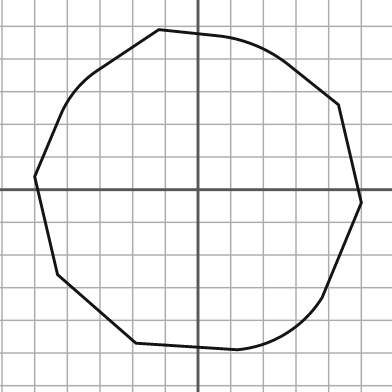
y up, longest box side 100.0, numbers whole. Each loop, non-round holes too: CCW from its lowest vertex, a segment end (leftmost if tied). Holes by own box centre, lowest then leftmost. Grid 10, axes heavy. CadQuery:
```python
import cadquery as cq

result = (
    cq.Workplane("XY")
    .moveTo(12.0, -49.0)
    .threePointArc((27.0, -44.0), (38.0, -33.0))
    .lineTo(50.0, -4.0)
    .lineTo(43.0, 26.0)
    .lineTo(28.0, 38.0)
    .threePointArc((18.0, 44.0), (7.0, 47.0))
    .lineTo(-12.0, 49.0)
    .lineTo(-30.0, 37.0)
    .threePointArc((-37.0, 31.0), (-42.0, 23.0))
    .lineTo(-50.0, 4.0)
    .lineTo(-43.0, -26.0)
    .lineTo(-19.0, -47.0)
    .close()
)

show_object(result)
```